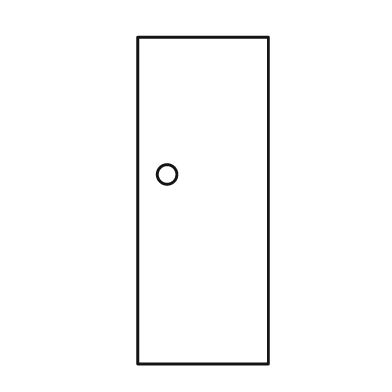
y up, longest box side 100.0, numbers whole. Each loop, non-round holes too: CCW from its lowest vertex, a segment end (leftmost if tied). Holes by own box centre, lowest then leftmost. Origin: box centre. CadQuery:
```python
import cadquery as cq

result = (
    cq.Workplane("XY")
    .moveTo(-20.0, -50.0)
    .lineTo(20.0, -50.0)
    .lineTo(20.0, 50.0)
    .lineTo(-20.0, 50.0)
    .close()
    .moveTo(-11.0, 8.0)
    .circle(3.0)
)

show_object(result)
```